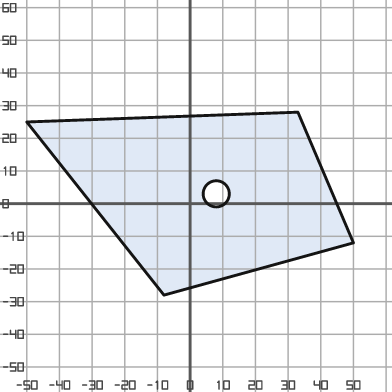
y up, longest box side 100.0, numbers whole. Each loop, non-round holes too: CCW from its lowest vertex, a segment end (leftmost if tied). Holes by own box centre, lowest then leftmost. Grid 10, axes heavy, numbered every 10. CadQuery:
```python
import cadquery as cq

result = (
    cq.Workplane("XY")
    .moveTo(-8.0, -28.0)
    .lineTo(50.0, -12.0)
    .lineTo(33.0, 28.0)
    .lineTo(-50.0, 25.0)
    .close()
    .moveTo(8.0, 3.0)
    .circle(4.0)
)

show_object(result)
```